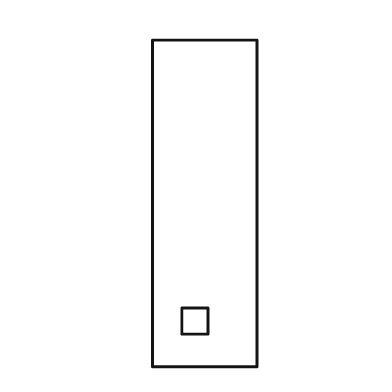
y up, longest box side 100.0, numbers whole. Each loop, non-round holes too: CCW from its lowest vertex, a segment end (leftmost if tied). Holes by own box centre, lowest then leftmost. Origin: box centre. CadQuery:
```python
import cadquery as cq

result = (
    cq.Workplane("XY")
    .moveTo(-16.0, -50.0)
    .lineTo(16.0, -50.0)
    .lineTo(16.0, 50.0)
    .lineTo(-16.0, 50.0)
    .close()
    .moveTo(-7.0, -40.0)
    .lineTo(1.0, -40.0)
    .lineTo(1.0, -32.0)
    .lineTo(-7.0, -32.0)
    .close()
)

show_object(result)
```